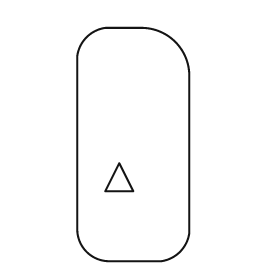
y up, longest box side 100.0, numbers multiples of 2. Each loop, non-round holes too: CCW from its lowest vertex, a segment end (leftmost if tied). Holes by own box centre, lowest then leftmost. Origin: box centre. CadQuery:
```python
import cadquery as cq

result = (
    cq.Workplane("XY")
    .moveTo(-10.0, -50.0)
    .lineTo(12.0, -50.0)
    .threePointArc((20.0, -46.0), (24.0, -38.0))
    .lineTo(24.0, 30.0)
    .threePointArc((18.0, 44.0), (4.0, 50.0))
    .lineTo(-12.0, 50.0)
    .threePointArc((-20.0, 46.0), (-24.0, 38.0))
    .lineTo(-24.0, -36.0)
    .threePointArc((-20.0, -46.0), (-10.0, -50.0))
    .close()
    .moveTo(-12.0, -20.0)
    .lineTo(0.0, -20.0)
    .lineTo(-6.0, -8.0)
    .close()
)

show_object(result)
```